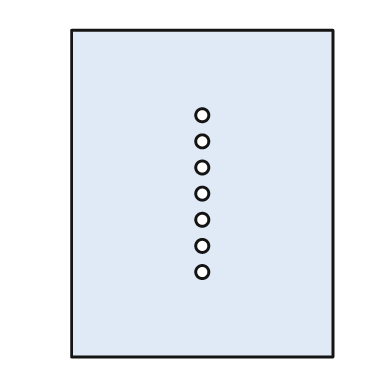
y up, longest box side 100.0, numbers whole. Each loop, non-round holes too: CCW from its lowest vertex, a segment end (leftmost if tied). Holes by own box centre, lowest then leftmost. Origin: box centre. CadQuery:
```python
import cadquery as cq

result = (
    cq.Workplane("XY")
    .moveTo(-40.0, -50.0)
    .lineTo(40.0, -50.0)
    .lineTo(40.0, 50.0)
    .lineTo(-40.0, 50.0)
    .close()
    .moveTo(0.0, -24.0)
    .circle(2.0)
    .moveTo(0.0, -16.0)
    .circle(2.0)
    .moveTo(0.0, -8.0)
    .circle(2.0)
    .moveTo(0.0, 0.0)
    .circle(2.0)
    .moveTo(0.0, 8.0)
    .circle(2.0)
    .moveTo(0.0, 16.0)
    .circle(2.0)
    .moveTo(0.0, 24.0)
    .circle(2.0)
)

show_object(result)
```